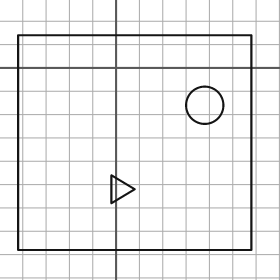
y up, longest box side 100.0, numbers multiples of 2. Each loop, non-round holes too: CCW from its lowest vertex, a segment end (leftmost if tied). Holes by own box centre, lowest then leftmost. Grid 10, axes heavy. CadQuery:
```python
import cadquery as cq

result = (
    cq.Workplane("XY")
    .moveTo(-42.0, -78.0)
    .lineTo(58.0, -78.0)
    .lineTo(58.0, 14.0)
    .lineTo(-42.0, 14.0)
    .close()
    .moveTo(-2.0, -58.0)
    .lineTo(8.0, -52.0)
    .lineTo(-2.0, -46.0)
    .close()
    .moveTo(38.0, -16.0)
    .circle(8.0)
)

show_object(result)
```